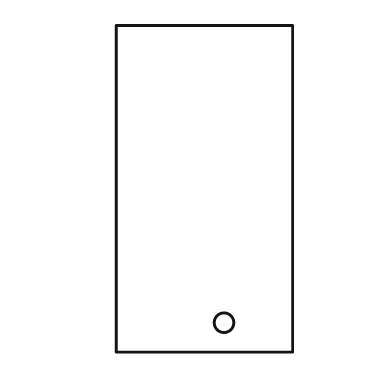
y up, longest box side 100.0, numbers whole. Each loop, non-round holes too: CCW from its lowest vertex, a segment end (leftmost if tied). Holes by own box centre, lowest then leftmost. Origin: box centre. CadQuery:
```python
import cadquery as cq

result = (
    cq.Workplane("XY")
    .moveTo(-27.0, -50.0)
    .lineTo(27.0, -50.0)
    .lineTo(27.0, 50.0)
    .lineTo(-27.0, 50.0)
    .close()
    .moveTo(6.0, -41.0)
    .circle(3.0)
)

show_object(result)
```